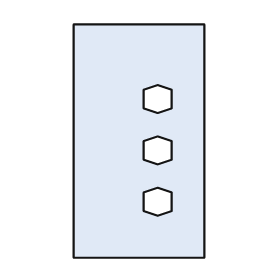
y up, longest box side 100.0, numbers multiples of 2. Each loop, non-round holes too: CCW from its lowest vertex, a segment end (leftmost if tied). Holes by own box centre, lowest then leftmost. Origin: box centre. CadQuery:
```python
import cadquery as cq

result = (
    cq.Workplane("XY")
    .moveTo(-28.0, -50.0)
    .lineTo(28.0, -50.0)
    .lineTo(28.0, 50.0)
    .lineTo(-28.0, 50.0)
    .close()
    .moveTo(8.0, -32.0)
    .lineTo(14.0, -30.0)
    .lineTo(14.0, -22.0)
    .lineTo(8.0, -20.0)
    .lineTo(2.0, -22.0)
    .lineTo(2.0, -30.0)
    .close()
    .moveTo(8.0, -10.0)
    .lineTo(14.0, -8.0)
    .lineTo(14.0, 0.0)
    .lineTo(8.0, 2.0)
    .lineTo(2.0, 0.0)
    .lineTo(2.0, -8.0)
    .close()
    .moveTo(8.0, 12.0)
    .lineTo(14.0, 14.0)
    .lineTo(14.0, 22.0)
    .lineTo(8.0, 24.0)
    .lineTo(2.0, 22.0)
    .lineTo(2.0, 14.0)
    .close()
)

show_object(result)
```